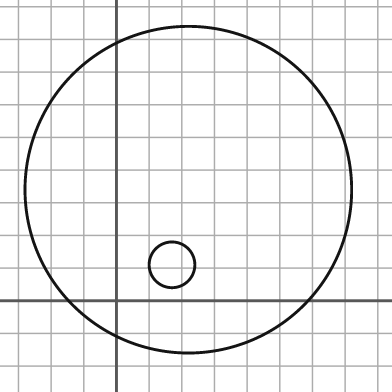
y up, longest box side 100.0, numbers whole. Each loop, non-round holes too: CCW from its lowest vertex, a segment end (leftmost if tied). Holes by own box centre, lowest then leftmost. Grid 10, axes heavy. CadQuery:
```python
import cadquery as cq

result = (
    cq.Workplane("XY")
    .moveTo(22.0, 34.0)
    .circle(50.0)
    .moveTo(17.0, 11.0)
    .circle(7.0)
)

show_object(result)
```